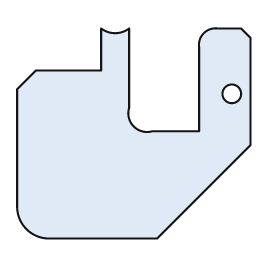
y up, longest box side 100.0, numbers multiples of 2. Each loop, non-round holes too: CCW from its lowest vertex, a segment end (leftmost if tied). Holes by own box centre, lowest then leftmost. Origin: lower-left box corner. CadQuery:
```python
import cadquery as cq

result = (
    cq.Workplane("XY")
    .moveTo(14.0, 0.0)
    .lineTo(60.0, 0.0)
    .lineTo(100.0, 40.0)
    .lineTo(100.0, 86.0)
    .lineTo(96.0, 90.0)
    .lineTo(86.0, 90.0)
    .threePointArc((80.0, 88.0), (78.0, 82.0))
    .lineTo(78.0, 46.0)
    .lineTo(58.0, 46.0)
    .threePointArc((50.0, 48.0), (48.0, 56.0))
    .lineTo(48.0, 90.0)
    .threePointArc((42.0, 88.0), (36.0, 90.0))
    .lineTo(36.0, 72.0)
    .lineTo(8.0, 72.0)
    .lineTo(0.0, 64.0)
    .lineTo(0.0, 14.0)
    .threePointArc((4.0, 4.0), (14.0, 0.0))
    .close()
    .moveTo(92.0, 62.0)
    .circle(4.0)
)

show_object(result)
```